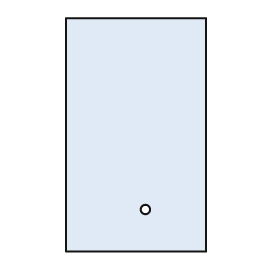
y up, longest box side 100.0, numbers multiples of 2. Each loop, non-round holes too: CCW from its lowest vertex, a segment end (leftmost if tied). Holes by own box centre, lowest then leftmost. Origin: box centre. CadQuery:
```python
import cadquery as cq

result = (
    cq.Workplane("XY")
    .moveTo(-30.0, -50.0)
    .lineTo(30.0, -50.0)
    .lineTo(30.0, 50.0)
    .lineTo(-30.0, 50.0)
    .close()
    .moveTo(4.0, -32.0)
    .circle(2.0)
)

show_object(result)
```